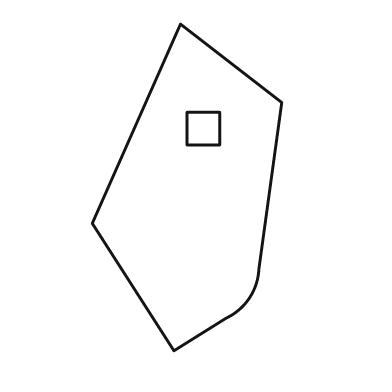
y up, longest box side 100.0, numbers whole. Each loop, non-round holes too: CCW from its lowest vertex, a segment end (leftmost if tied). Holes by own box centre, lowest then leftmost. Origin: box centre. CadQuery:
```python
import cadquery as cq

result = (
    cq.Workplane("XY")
    .moveTo(-4.0, -50.0)
    .lineTo(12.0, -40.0)
    .threePointArc((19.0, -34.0), (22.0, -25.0))
    .lineTo(29.0, 26.0)
    .lineTo(-2.0, 50.0)
    .lineTo(-29.0, -11.0)
    .close()
    .moveTo(0.0, 13.0)
    .lineTo(10.0, 13.0)
    .lineTo(10.0, 23.0)
    .lineTo(0.0, 23.0)
    .close()
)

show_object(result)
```